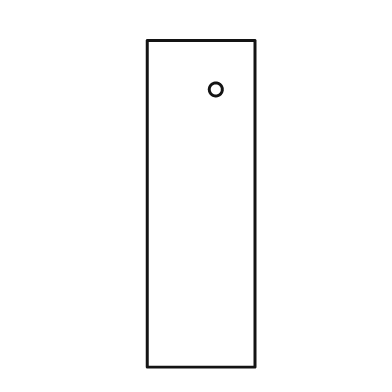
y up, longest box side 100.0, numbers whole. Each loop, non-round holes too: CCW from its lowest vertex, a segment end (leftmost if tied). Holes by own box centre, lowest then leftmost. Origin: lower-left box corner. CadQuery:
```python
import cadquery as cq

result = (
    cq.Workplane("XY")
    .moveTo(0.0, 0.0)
    .lineTo(33.0, 0.0)
    .lineTo(33.0, 100.0)
    .lineTo(0.0, 100.0)
    .close()
    .moveTo(21.0, 85.0)
    .circle(2.0)
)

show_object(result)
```